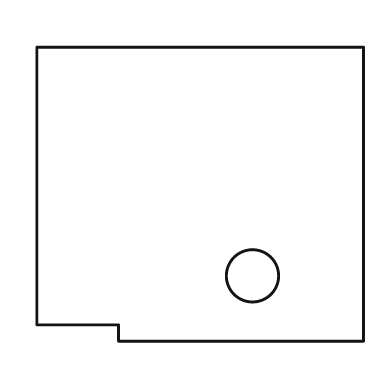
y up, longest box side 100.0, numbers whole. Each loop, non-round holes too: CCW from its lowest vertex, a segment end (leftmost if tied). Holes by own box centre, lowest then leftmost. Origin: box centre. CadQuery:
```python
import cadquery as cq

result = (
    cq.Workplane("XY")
    .moveTo(-25.0, -45.0)
    .lineTo(50.0, -45.0)
    .lineTo(50.0, 45.0)
    .lineTo(-50.0, 45.0)
    .lineTo(-50.0, -40.0)
    .lineTo(-25.0, -40.0)
    .close()
    .moveTo(16.0, -25.0)
    .circle(8.0)
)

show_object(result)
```